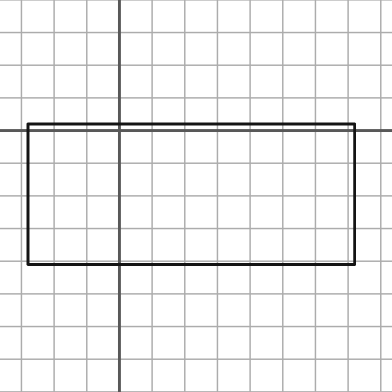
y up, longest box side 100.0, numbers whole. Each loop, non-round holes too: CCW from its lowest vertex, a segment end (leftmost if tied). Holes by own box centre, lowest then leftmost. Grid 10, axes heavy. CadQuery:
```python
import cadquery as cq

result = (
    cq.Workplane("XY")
    .moveTo(-28.0, -41.0)
    .lineTo(72.0, -41.0)
    .lineTo(72.0, 2.0)
    .lineTo(-28.0, 2.0)
    .close()
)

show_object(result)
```